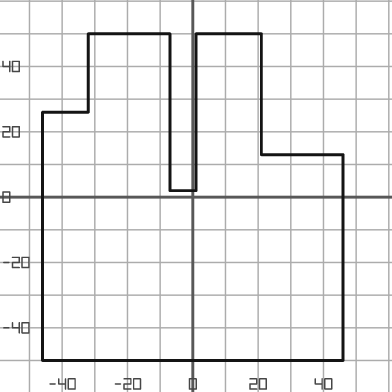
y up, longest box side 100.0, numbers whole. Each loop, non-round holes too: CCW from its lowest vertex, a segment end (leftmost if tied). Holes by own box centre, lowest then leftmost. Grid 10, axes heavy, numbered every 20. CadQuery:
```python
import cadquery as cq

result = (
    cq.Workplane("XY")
    .moveTo(-46.0, -50.0)
    .lineTo(46.0, -50.0)
    .lineTo(46.0, 13.0)
    .lineTo(21.0, 13.0)
    .lineTo(21.0, 50.0)
    .lineTo(1.0, 50.0)
    .lineTo(1.0, 2.0)
    .lineTo(-7.0, 2.0)
    .lineTo(-7.0, 50.0)
    .lineTo(-32.0, 50.0)
    .lineTo(-32.0, 26.0)
    .lineTo(-46.0, 26.0)
    .close()
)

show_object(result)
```